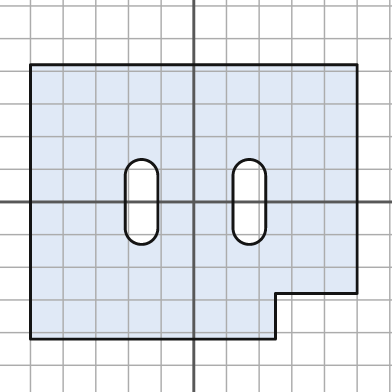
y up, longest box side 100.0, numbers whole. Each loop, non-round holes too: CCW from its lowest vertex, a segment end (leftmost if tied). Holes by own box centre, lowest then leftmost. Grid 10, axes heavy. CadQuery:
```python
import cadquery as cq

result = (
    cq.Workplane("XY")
    .moveTo(-50.0, -42.0)
    .lineTo(25.0, -42.0)
    .lineTo(25.0, -28.0)
    .lineTo(50.0, -28.0)
    .lineTo(50.0, 42.0)
    .lineTo(-50.0, 42.0)
    .close()
    .moveTo(-21.0, -8.0)
    .threePointArc((-16.0, -13.0), (-11.0, -8.0))
    .lineTo(-11.0, 8.0)
    .threePointArc((-16.0, 13.0), (-21.0, 8.0))
    .close()
    .moveTo(12.0, -8.0)
    .threePointArc((17.0, -13.0), (22.0, -8.0))
    .lineTo(22.0, 8.0)
    .threePointArc((17.0, 13.0), (12.0, 8.0))
    .close()
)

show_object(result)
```